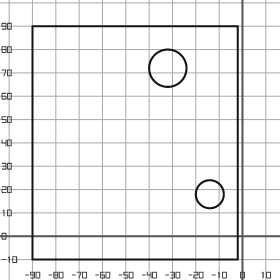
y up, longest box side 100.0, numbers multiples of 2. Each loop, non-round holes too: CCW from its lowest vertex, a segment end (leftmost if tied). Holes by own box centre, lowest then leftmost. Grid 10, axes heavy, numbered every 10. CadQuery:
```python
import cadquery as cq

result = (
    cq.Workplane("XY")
    .moveTo(-90.0, -10.0)
    .lineTo(-2.0, -10.0)
    .lineTo(-2.0, 90.0)
    .lineTo(-90.0, 90.0)
    .close()
    .moveTo(-14.0, 18.0)
    .circle(6.0)
    .moveTo(-32.0, 72.0)
    .circle(8.0)
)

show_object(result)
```